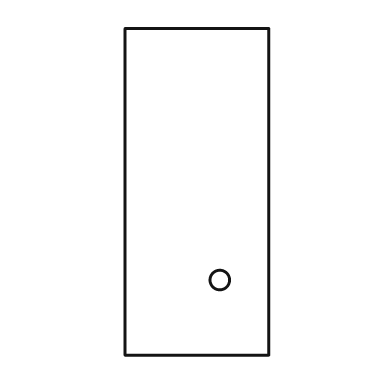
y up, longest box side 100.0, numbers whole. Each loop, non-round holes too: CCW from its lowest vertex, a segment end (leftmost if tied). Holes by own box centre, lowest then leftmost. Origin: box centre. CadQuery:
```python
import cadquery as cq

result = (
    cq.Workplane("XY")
    .moveTo(-22.0, -50.0)
    .lineTo(22.0, -50.0)
    .lineTo(22.0, 50.0)
    .lineTo(-22.0, 50.0)
    .close()
    .moveTo(7.0, -27.0)
    .circle(3.0)
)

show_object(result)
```